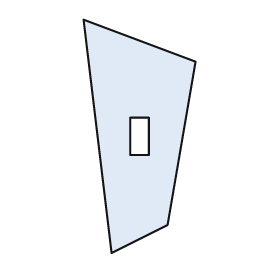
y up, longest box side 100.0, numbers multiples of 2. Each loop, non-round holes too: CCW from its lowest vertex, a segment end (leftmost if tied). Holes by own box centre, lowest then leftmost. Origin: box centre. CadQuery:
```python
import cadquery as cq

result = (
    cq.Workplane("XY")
    .moveTo(-12.0, -50.0)
    .lineTo(12.0, -38.0)
    .lineTo(24.0, 32.0)
    .lineTo(-24.0, 50.0)
    .close()
    .moveTo(-4.0, -8.0)
    .lineTo(4.0, -8.0)
    .lineTo(4.0, 8.0)
    .lineTo(-4.0, 8.0)
    .close()
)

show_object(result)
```